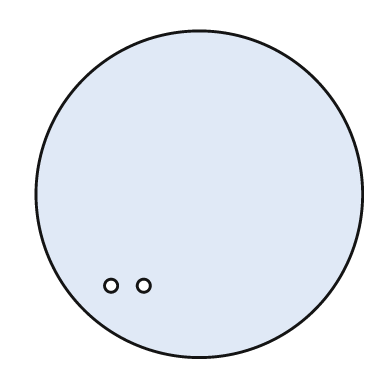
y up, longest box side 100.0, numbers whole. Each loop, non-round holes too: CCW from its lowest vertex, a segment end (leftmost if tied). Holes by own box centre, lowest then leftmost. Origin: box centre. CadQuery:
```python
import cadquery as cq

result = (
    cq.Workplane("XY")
    .moveTo(0.0, 0.0)
    .circle(50.0)
    .moveTo(-27.0, -28.0)
    .circle(2.0)
    .moveTo(-17.0, -28.0)
    .circle(2.0)
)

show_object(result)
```